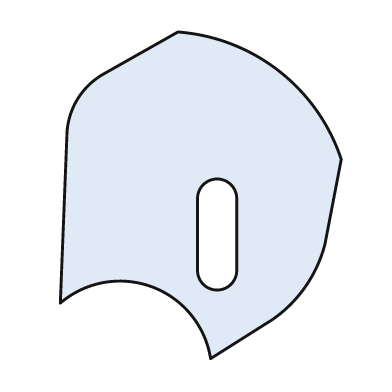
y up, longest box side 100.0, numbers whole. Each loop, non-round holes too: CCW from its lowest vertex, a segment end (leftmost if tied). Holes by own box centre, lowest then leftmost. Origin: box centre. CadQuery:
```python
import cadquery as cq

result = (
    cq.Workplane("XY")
    .moveTo(3.0, -50.0)
    .lineTo(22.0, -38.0)
    .threePointArc((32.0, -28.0), (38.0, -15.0))
    .lineTo(43.0, 11.0)
    .threePointArc((24.0, 38.0), (-7.0, 50.0))
    .lineTo(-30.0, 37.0)
    .threePointArc((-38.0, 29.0), (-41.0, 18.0))
    .lineTo(-43.0, -33.0)
    .threePointArc((-15.0, -28.0), (3.0, -50.0))
    .close()
    .moveTo(-1.0, -23.0)
    .threePointArc((5.0, -29.0), (11.0, -23.0))
    .lineTo(11.0, -1.0)
    .threePointArc((5.0, 5.0), (-1.0, -1.0))
    .close()
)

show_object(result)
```